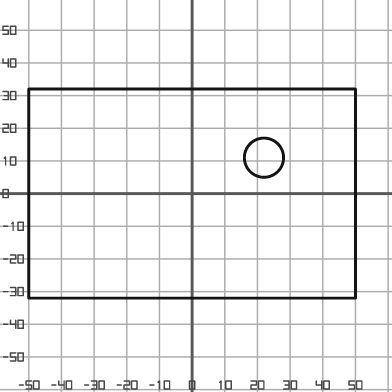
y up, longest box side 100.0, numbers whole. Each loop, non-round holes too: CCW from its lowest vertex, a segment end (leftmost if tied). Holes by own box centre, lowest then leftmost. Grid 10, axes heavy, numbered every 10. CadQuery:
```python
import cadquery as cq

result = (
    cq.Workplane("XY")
    .moveTo(-50.0, -32.0)
    .lineTo(50.0, -32.0)
    .lineTo(50.0, 32.0)
    .lineTo(-50.0, 32.0)
    .close()
    .moveTo(22.0, 11.0)
    .circle(6.0)
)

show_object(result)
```